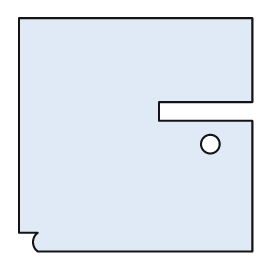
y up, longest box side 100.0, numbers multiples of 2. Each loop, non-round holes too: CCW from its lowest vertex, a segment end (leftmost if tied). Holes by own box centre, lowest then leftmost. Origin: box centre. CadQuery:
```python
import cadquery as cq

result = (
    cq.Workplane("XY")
    .moveTo(-42.0, -50.0)
    .lineTo(50.0, -50.0)
    .lineTo(50.0, 6.0)
    .lineTo(10.0, 6.0)
    .lineTo(10.0, 14.0)
    .lineTo(50.0, 14.0)
    .lineTo(50.0, 50.0)
    .lineTo(-50.0, 50.0)
    .lineTo(-50.0, -42.0)
    .lineTo(-42.0, -42.0)
    .threePointArc((-44.0, -46.0), (-42.0, -50.0))
    .close()
    .moveTo(32.0, -4.0)
    .circle(4.0)
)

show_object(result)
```